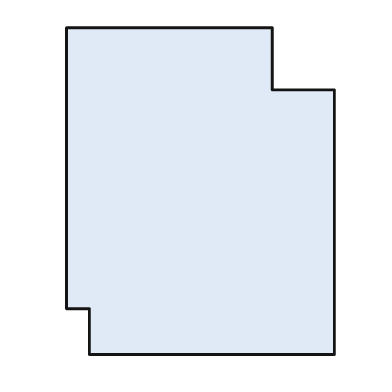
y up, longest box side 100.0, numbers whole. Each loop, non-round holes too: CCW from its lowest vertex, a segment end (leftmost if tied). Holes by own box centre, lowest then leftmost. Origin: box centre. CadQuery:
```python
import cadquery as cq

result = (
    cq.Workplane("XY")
    .moveTo(-34.0, -50.0)
    .lineTo(41.0, -50.0)
    .lineTo(41.0, 31.0)
    .lineTo(22.0, 31.0)
    .lineTo(22.0, 50.0)
    .lineTo(-41.0, 50.0)
    .lineTo(-41.0, -36.0)
    .lineTo(-34.0, -36.0)
    .close()
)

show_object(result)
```